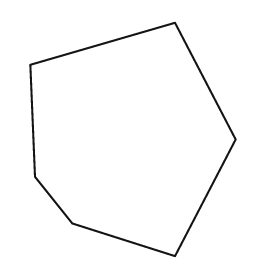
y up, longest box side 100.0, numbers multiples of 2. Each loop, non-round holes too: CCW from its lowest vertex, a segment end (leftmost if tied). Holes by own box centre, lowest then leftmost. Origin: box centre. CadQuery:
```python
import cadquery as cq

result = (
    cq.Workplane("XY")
    .moveTo(18.0, -50.0)
    .lineTo(44.0, 0.0)
    .lineTo(18.0, 50.0)
    .lineTo(-44.0, 32.0)
    .lineTo(-42.0, -16.0)
    .lineTo(-26.0, -36.0)
    .close()
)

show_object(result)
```